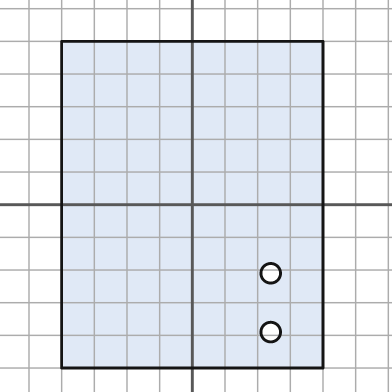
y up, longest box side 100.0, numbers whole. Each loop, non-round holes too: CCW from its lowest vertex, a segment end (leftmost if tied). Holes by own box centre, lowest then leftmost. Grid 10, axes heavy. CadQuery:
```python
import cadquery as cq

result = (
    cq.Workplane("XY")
    .moveTo(-40.0, -50.0)
    .lineTo(40.0, -50.0)
    .lineTo(40.0, 50.0)
    .lineTo(-40.0, 50.0)
    .close()
    .moveTo(24.0, -39.0)
    .circle(3.0)
    .moveTo(24.0, -21.0)
    .circle(3.0)
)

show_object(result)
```